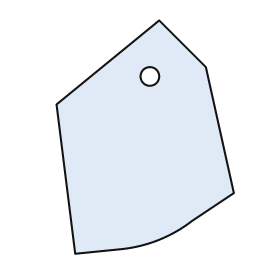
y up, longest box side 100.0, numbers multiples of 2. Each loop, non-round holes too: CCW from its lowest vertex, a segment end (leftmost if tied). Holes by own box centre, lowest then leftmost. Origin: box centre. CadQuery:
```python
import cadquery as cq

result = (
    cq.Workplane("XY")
    .moveTo(-30.0, -50.0)
    .lineTo(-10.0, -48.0)
    .threePointArc((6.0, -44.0), (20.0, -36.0))
    .lineTo(38.0, -24.0)
    .lineTo(26.0, 30.0)
    .lineTo(6.0, 50.0)
    .lineTo(-38.0, 14.0)
    .close()
    .moveTo(2.0, 26.0)
    .circle(4.0)
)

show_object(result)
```